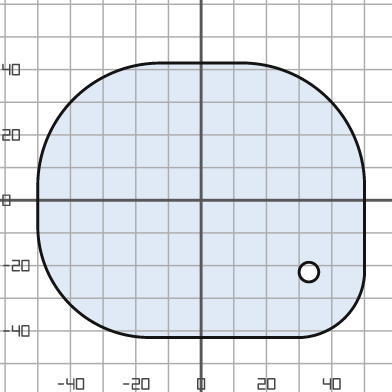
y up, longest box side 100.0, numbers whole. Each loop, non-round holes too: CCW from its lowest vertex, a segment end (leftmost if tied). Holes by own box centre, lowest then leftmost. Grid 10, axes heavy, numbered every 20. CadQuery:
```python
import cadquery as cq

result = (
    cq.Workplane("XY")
    .moveTo(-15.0, -42.0)
    .lineTo(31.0, -42.0)
    .threePointArc((44.0, -36.0), (50.0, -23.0))
    .lineTo(50.0, 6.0)
    .threePointArc((39.0, 31.0), (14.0, 42.0))
    .lineTo(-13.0, 42.0)
    .threePointArc((-39.0, 31.0), (-50.0, 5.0))
    .lineTo(-50.0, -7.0)
    .threePointArc((-40.0, -32.0), (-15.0, -42.0))
    .close()
    .moveTo(33.0, -22.0)
    .circle(3.0)
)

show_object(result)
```